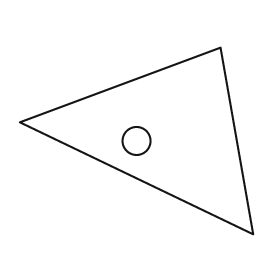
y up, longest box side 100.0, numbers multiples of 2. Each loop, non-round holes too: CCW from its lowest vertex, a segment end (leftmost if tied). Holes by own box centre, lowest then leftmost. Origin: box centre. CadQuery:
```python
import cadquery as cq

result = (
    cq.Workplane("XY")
    .moveTo(50.0, -40.0)
    .lineTo(36.0, 40.0)
    .lineTo(-50.0, 8.0)
    .close()
    .moveTo(0.0, 0.0)
    .circle(6.0)
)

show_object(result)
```